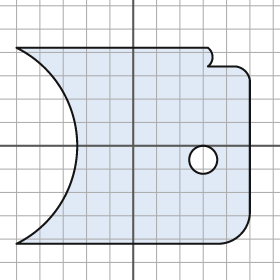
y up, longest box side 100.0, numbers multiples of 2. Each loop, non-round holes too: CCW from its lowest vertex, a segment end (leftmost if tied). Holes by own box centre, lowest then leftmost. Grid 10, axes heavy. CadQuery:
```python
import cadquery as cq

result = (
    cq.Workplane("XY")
    .moveTo(-50.0, -42.0)
    .lineTo(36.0, -42.0)
    .threePointArc((46.0, -38.0), (50.0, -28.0))
    .lineTo(50.0, 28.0)
    .threePointArc((48.0, 32.0), (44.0, 34.0))
    .lineTo(32.0, 34.0)
    .threePointArc((34.0, 38.0), (32.0, 42.0))
    .lineTo(-50.0, 42.0)
    .threePointArc((-24.0, 0.0), (-50.0, -42.0))
    .close()
    .moveTo(30.0, -6.0)
    .circle(6.0)
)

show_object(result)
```